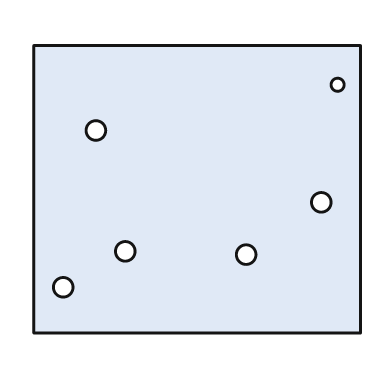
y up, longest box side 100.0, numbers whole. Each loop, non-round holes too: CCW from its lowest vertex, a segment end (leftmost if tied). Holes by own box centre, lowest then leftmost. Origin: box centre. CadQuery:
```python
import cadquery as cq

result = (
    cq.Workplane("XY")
    .moveTo(-50.0, -44.0)
    .lineTo(50.0, -44.0)
    .lineTo(50.0, 44.0)
    .lineTo(-50.0, 44.0)
    .close()
    .moveTo(-41.0, -30.0)
    .circle(3.0)
    .moveTo(15.0, -20.0)
    .circle(3.0)
    .moveTo(-22.0, -19.0)
    .circle(3.0)
    .moveTo(38.0, -4.0)
    .circle(3.0)
    .moveTo(-31.0, 18.0)
    .circle(3.0)
    .moveTo(43.0, 32.0)
    .circle(2.0)
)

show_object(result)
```